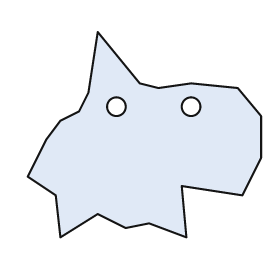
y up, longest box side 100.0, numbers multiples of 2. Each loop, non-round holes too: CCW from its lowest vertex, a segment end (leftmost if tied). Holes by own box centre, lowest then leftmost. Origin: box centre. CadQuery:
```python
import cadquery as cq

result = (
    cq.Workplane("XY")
    .moveTo(-36.0, -44.0)
    .lineTo(-20.0, -34.0)
    .lineTo(-8.0, -40.0)
    .lineTo(2.0, -38.0)
    .lineTo(18.0, -44.0)
    .lineTo(16.0, -22.0)
    .lineTo(42.0, -26.0)
    .lineTo(50.0, -10.0)
    .lineTo(50.0, 8.0)
    .lineTo(40.0, 20.0)
    .lineTo(20.0, 22.0)
    .lineTo(6.0, 20.0)
    .lineTo(-2.0, 22.0)
    .lineTo(-20.0, 44.0)
    .lineTo(-24.0, 18.0)
    .lineTo(-28.0, 10.0)
    .lineTo(-36.0, 6.0)
    .lineTo(-42.0, -2.0)
    .lineTo(-50.0, -18.0)
    .lineTo(-38.0, -26.0)
    .close()
    .moveTo(-12.0, 12.0)
    .circle(4.0)
    .moveTo(20.0, 12.0)
    .circle(4.0)
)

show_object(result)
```